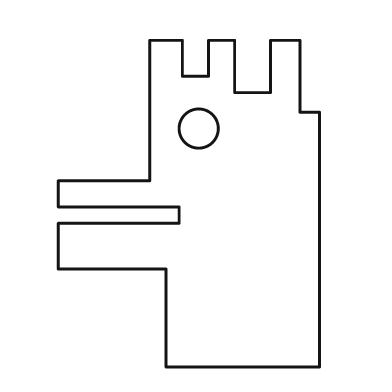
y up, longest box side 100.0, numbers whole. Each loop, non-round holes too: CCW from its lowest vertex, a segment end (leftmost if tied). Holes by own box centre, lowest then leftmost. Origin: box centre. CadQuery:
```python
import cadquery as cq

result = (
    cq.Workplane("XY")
    .moveTo(-7.0, -50.0)
    .lineTo(40.0, -50.0)
    .lineTo(40.0, 28.0)
    .lineTo(34.0, 28.0)
    .lineTo(34.0, 50.0)
    .lineTo(25.0, 50.0)
    .lineTo(25.0, 34.0)
    .lineTo(14.0, 34.0)
    .lineTo(14.0, 50.0)
    .lineTo(6.0, 50.0)
    .lineTo(6.0, 39.0)
    .lineTo(-2.0, 39.0)
    .lineTo(-2.0, 50.0)
    .lineTo(-12.0, 50.0)
    .lineTo(-12.0, 7.0)
    .lineTo(-40.0, 7.0)
    .lineTo(-40.0, -1.0)
    .lineTo(-3.0, -1.0)
    .lineTo(-3.0, -6.0)
    .lineTo(-40.0, -6.0)
    .lineTo(-40.0, -20.0)
    .lineTo(-7.0, -20.0)
    .close()
    .moveTo(3.0, 23.0)
    .circle(6.0)
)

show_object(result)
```